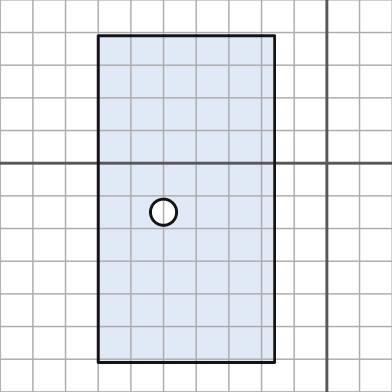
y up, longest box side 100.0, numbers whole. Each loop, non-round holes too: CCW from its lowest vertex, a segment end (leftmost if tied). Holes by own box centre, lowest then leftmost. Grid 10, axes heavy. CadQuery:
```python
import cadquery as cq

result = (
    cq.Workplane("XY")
    .moveTo(-70.0, -61.0)
    .lineTo(-16.0, -61.0)
    .lineTo(-16.0, 39.0)
    .lineTo(-70.0, 39.0)
    .close()
    .moveTo(-50.0, -15.0)
    .circle(4.0)
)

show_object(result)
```